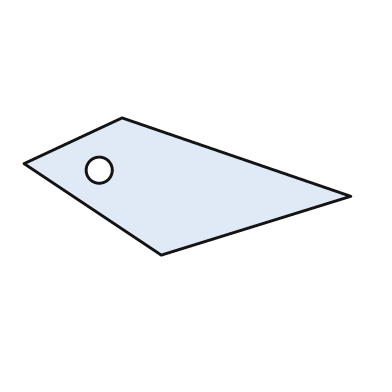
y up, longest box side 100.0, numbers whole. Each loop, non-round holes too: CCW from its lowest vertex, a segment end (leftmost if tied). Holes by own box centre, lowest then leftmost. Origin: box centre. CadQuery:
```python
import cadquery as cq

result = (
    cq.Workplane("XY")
    .moveTo(-8.0, -21.0)
    .lineTo(50.0, -3.0)
    .lineTo(-20.0, 21.0)
    .lineTo(-50.0, 7.0)
    .close()
    .moveTo(-27.0, 5.0)
    .circle(4.0)
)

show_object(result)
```